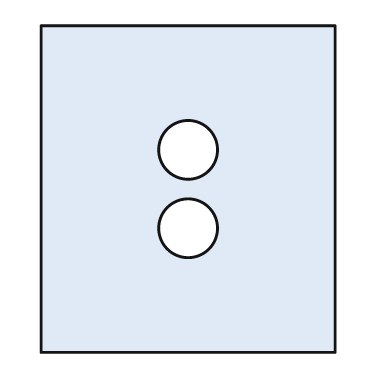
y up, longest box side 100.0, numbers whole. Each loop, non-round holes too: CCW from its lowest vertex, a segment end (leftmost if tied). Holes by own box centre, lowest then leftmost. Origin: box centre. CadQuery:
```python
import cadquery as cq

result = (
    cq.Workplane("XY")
    .moveTo(-45.0, -50.0)
    .lineTo(45.0, -50.0)
    .lineTo(45.0, 50.0)
    .lineTo(-45.0, 50.0)
    .close()
    .moveTo(0.0, -12.0)
    .circle(9.0)
    .moveTo(0.0, 12.0)
    .circle(9.0)
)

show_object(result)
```